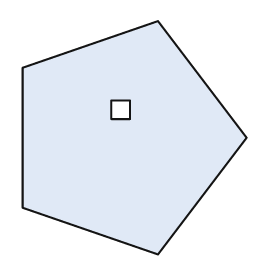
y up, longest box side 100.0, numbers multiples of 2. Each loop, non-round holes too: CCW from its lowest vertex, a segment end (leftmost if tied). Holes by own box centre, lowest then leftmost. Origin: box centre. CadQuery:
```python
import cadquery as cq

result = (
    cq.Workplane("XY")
    .moveTo(10.0, -50.0)
    .lineTo(48.0, 0.0)
    .lineTo(10.0, 50.0)
    .lineTo(-48.0, 30.0)
    .lineTo(-48.0, -30.0)
    .close()
    .moveTo(-10.0, 8.0)
    .lineTo(-2.0, 8.0)
    .lineTo(-2.0, 16.0)
    .lineTo(-10.0, 16.0)
    .close()
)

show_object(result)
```